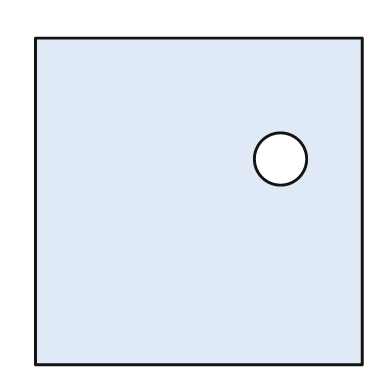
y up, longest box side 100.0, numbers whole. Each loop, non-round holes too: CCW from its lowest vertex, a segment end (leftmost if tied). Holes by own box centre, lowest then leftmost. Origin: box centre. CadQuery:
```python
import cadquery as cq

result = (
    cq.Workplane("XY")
    .moveTo(-50.0, -50.0)
    .lineTo(50.0, -50.0)
    .lineTo(50.0, 50.0)
    .lineTo(-50.0, 50.0)
    .close()
    .moveTo(25.0, 13.0)
    .circle(8.0)
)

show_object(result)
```